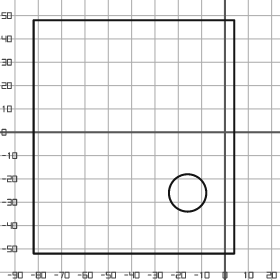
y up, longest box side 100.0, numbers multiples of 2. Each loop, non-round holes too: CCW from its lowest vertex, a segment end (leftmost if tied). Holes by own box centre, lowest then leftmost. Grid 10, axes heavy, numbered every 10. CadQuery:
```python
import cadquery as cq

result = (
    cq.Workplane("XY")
    .moveTo(-82.0, -52.0)
    .lineTo(4.0, -52.0)
    .lineTo(4.0, 48.0)
    .lineTo(-82.0, 48.0)
    .close()
    .moveTo(-16.0, -26.0)
    .circle(8.0)
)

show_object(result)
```